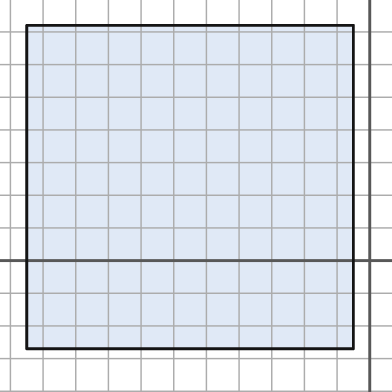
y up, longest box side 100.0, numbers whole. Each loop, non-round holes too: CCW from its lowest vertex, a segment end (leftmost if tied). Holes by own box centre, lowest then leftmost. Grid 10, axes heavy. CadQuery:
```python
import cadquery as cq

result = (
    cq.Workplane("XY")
    .moveTo(-105.0, -27.0)
    .lineTo(-5.0, -27.0)
    .lineTo(-5.0, 72.0)
    .lineTo(-105.0, 72.0)
    .close()
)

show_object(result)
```